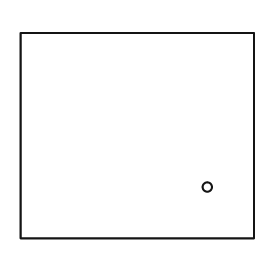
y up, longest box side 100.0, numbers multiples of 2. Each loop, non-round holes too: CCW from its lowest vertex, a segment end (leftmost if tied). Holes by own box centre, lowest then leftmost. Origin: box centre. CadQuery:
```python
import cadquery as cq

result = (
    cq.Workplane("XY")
    .moveTo(-50.0, -44.0)
    .lineTo(50.0, -44.0)
    .lineTo(50.0, 44.0)
    .lineTo(-50.0, 44.0)
    .close()
    .moveTo(30.0, -22.0)
    .circle(2.0)
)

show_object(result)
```